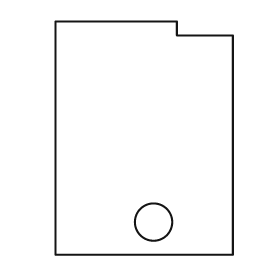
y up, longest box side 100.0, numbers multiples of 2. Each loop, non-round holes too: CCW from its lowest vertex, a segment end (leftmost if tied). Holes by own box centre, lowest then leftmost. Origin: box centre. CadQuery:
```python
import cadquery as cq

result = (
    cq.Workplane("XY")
    .moveTo(-38.0, -50.0)
    .lineTo(38.0, -50.0)
    .lineTo(38.0, 44.0)
    .lineTo(14.0, 44.0)
    .lineTo(14.0, 50.0)
    .lineTo(-38.0, 50.0)
    .close()
    .moveTo(4.0, -36.0)
    .circle(8.0)
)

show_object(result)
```